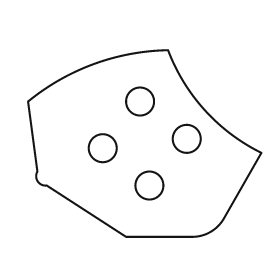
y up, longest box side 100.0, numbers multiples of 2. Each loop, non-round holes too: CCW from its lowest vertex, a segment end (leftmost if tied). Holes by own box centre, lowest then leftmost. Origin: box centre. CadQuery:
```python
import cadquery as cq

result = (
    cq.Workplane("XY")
    .moveTo(-8.0, -40.0)
    .lineTo(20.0, -40.0)
    .threePointArc((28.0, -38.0), (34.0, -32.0))
    .lineTo(50.0, -4.0)
    .threePointArc((26.0, 14.0), (10.0, 40.0))
    .threePointArc((-22.0, 34.0), (-50.0, 18.0))
    .lineTo(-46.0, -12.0)
    .threePointArc((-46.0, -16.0), (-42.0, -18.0))
    .close()
    .moveTo(2.0, -18.0)
    .circle(6.0)
    .moveTo(-18.0, -2.0)
    .circle(6.0)
    .moveTo(18.0, 2.0)
    .circle(6.0)
    .moveTo(-2.0, 18.0)
    .circle(6.0)
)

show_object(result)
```